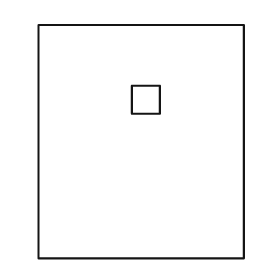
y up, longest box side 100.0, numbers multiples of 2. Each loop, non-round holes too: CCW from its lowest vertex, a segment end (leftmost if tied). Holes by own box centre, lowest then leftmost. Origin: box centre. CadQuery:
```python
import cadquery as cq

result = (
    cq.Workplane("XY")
    .moveTo(-44.0, -50.0)
    .lineTo(44.0, -50.0)
    .lineTo(44.0, 50.0)
    .lineTo(-44.0, 50.0)
    .close()
    .moveTo(-4.0, 12.0)
    .lineTo(8.0, 12.0)
    .lineTo(8.0, 24.0)
    .lineTo(-4.0, 24.0)
    .close()
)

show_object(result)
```